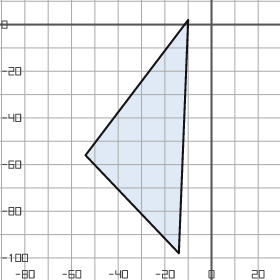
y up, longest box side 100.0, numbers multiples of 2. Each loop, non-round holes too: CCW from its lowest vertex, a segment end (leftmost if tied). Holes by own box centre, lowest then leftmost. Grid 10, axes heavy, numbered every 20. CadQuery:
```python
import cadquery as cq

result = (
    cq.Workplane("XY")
    .moveTo(-14.0, -98.0)
    .lineTo(-10.0, 2.0)
    .lineTo(-54.0, -56.0)
    .close()
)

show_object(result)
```